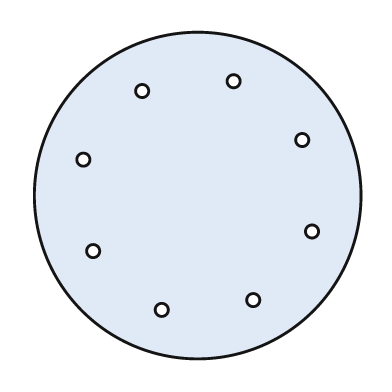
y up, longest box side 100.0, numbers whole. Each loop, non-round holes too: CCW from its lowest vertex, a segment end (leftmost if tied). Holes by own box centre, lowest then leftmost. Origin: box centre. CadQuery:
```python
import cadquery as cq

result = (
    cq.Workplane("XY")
    .moveTo(0.0, 0.0)
    .circle(50.0)
    .moveTo(-11.0, -35.0)
    .circle(2.0)
    .moveTo(17.0, -32.0)
    .circle(2.0)
    .moveTo(-32.0, -17.0)
    .circle(2.0)
    .moveTo(35.0, -11.0)
    .circle(2.0)
    .moveTo(-35.0, 11.0)
    .circle(2.0)
    .moveTo(32.0, 17.0)
    .circle(2.0)
    .moveTo(-17.0, 32.0)
    .circle(2.0)
    .moveTo(11.0, 35.0)
    .circle(2.0)
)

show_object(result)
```